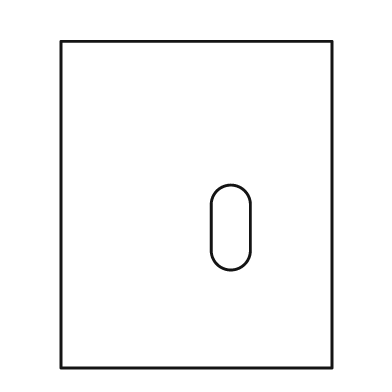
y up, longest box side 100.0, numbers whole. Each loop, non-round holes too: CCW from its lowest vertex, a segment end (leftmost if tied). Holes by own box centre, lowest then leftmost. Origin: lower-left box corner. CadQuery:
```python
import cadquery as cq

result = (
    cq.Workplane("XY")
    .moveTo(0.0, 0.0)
    .lineTo(83.0, 0.0)
    .lineTo(83.0, 100.0)
    .lineTo(0.0, 100.0)
    .close()
    .moveTo(46.0, 36.0)
    .threePointArc((52.0, 30.0), (58.0, 36.0))
    .lineTo(58.0, 50.0)
    .threePointArc((52.0, 56.0), (46.0, 50.0))
    .close()
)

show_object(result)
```